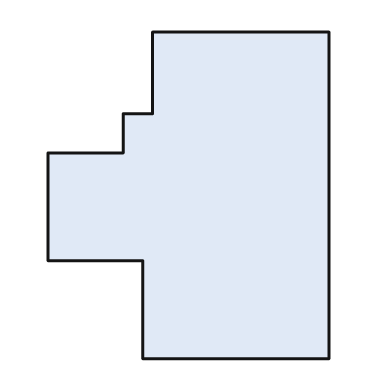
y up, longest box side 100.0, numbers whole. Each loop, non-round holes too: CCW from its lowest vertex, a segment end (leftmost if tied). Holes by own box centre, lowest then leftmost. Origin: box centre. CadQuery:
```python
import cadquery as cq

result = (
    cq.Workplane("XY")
    .moveTo(-14.0, -50.0)
    .lineTo(43.0, -50.0)
    .lineTo(43.0, 50.0)
    .lineTo(-11.0, 50.0)
    .lineTo(-11.0, 25.0)
    .lineTo(-20.0, 25.0)
    .lineTo(-20.0, 13.0)
    .lineTo(-43.0, 13.0)
    .lineTo(-43.0, -20.0)
    .lineTo(-14.0, -20.0)
    .close()
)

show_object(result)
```